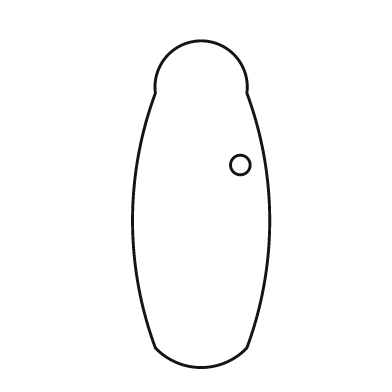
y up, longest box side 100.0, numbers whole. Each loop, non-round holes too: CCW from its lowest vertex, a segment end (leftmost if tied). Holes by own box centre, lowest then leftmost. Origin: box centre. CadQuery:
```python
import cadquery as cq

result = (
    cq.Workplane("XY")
    .moveTo(-14.0, -44.0)
    .threePointArc((0.0, -50.0), (14.0, -44.0))
    .threePointArc((21.0, -5.0), (14.0, 34.0))
    .threePointArc((0.0, 50.0), (-14.0, 34.0))
    .threePointArc((-21.0, -5.0), (-14.0, -44.0))
    .close()
    .moveTo(12.0, 12.0)
    .circle(3.0)
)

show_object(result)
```